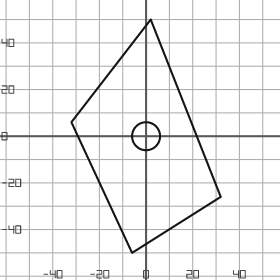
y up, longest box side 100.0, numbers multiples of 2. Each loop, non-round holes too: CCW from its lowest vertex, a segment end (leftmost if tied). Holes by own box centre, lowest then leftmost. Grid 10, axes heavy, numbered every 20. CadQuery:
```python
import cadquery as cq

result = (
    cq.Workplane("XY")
    .moveTo(-6.0, -50.0)
    .lineTo(32.0, -26.0)
    .lineTo(2.0, 50.0)
    .lineTo(-32.0, 6.0)
    .close()
    .moveTo(0.0, 0.0)
    .circle(6.0)
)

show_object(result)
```